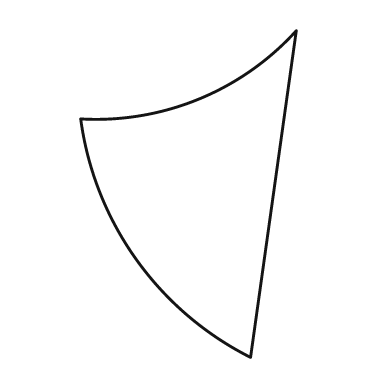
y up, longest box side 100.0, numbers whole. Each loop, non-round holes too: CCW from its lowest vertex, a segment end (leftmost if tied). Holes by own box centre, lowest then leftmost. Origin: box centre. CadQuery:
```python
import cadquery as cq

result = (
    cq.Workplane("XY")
    .moveTo(19.0, -50.0)
    .lineTo(33.0, 50.0)
    .threePointArc((3.0, 29.0), (-33.0, 23.0))
    .threePointArc((-16.0, -20.0), (19.0, -50.0))
    .close()
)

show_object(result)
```